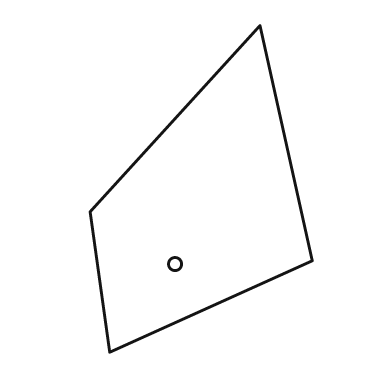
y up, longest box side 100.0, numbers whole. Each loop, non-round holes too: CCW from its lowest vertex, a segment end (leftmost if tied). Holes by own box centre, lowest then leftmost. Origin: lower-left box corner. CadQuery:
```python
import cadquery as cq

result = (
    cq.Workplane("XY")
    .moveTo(6.0, 0.0)
    .lineTo(68.0, 28.0)
    .lineTo(52.0, 100.0)
    .lineTo(0.0, 43.0)
    .close()
    .moveTo(26.0, 27.0)
    .circle(2.0)
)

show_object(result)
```